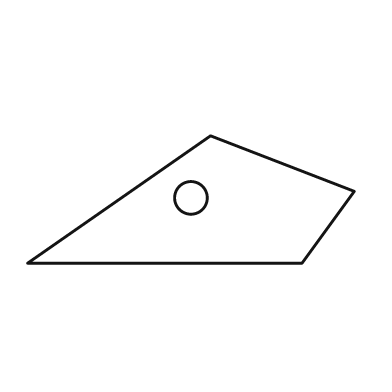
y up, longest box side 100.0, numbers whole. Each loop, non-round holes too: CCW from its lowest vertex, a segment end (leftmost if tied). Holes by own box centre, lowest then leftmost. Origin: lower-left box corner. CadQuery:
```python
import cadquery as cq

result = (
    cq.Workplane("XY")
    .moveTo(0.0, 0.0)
    .lineTo(84.0, 0.0)
    .lineTo(100.0, 22.0)
    .lineTo(56.0, 39.0)
    .close()
    .moveTo(50.0, 20.0)
    .circle(5.0)
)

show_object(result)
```